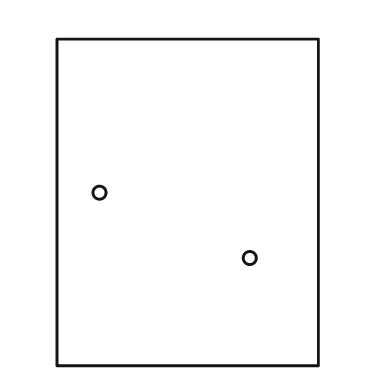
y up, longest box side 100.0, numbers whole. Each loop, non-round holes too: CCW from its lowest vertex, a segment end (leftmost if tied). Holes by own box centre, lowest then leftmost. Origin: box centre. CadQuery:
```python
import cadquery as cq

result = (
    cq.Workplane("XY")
    .moveTo(-40.0, -50.0)
    .lineTo(40.0, -50.0)
    .lineTo(40.0, 50.0)
    .lineTo(-40.0, 50.0)
    .close()
    .moveTo(19.0, -17.0)
    .circle(2.0)
    .moveTo(-27.0, 3.0)
    .circle(2.0)
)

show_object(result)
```